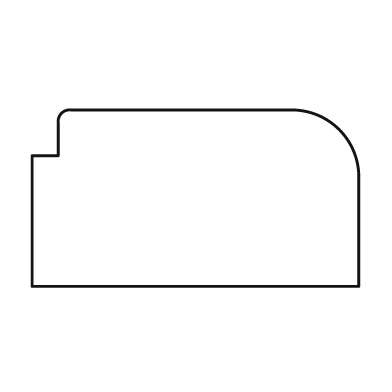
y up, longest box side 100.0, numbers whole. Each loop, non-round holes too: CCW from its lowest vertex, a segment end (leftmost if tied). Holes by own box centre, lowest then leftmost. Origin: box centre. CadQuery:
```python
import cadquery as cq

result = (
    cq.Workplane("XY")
    .moveTo(-50.0, -27.0)
    .lineTo(50.0, -27.0)
    .lineTo(50.0, 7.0)
    .threePointArc((44.0, 21.0), (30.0, 27.0))
    .lineTo(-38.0, 27.0)
    .threePointArc((-41.0, 26.0), (-42.0, 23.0))
    .lineTo(-42.0, 13.0)
    .lineTo(-50.0, 13.0)
    .close()
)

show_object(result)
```